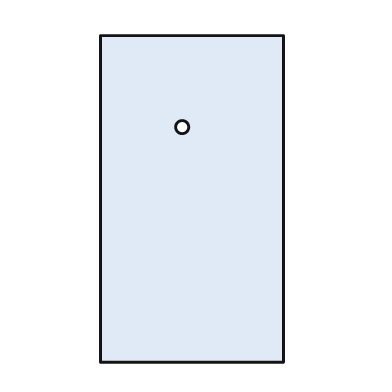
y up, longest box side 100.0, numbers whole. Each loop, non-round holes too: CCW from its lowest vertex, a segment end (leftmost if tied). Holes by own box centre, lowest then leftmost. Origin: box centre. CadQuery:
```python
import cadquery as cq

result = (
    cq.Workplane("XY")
    .moveTo(-28.0, -50.0)
    .lineTo(28.0, -50.0)
    .lineTo(28.0, 50.0)
    .lineTo(-28.0, 50.0)
    .close()
    .moveTo(-3.0, 22.0)
    .circle(2.0)
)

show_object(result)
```